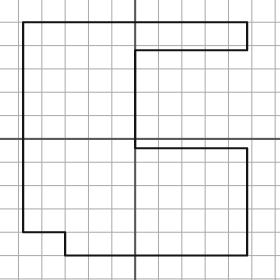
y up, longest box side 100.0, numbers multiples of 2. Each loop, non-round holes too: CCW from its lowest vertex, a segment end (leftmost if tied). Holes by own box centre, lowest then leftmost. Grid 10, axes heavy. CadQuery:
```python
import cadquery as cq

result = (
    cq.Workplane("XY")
    .moveTo(-30.0, -50.0)
    .lineTo(48.0, -50.0)
    .lineTo(48.0, -4.0)
    .lineTo(0.0, -4.0)
    .lineTo(0.0, 38.0)
    .lineTo(48.0, 38.0)
    .lineTo(48.0, 50.0)
    .lineTo(-48.0, 50.0)
    .lineTo(-48.0, -40.0)
    .lineTo(-30.0, -40.0)
    .close()
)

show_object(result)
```